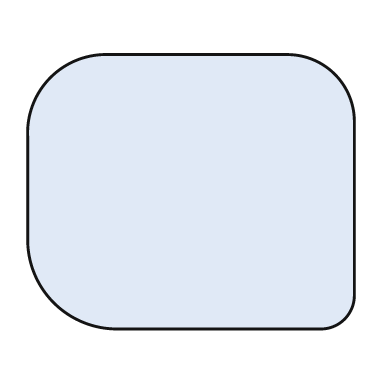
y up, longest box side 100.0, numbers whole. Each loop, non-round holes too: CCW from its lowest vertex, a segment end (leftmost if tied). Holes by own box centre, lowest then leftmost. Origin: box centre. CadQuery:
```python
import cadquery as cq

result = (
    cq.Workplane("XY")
    .moveTo(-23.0, -42.0)
    .lineTo(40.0, -42.0)
    .threePointArc((47.0, -39.0), (50.0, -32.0))
    .lineTo(50.0, 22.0)
    .threePointArc((44.0, 36.0), (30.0, 42.0))
    .lineTo(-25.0, 42.0)
    .threePointArc((-43.0, 35.0), (-50.0, 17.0))
    .lineTo(-50.0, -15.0)
    .threePointArc((-42.0, -34.0), (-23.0, -42.0))
    .close()
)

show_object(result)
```